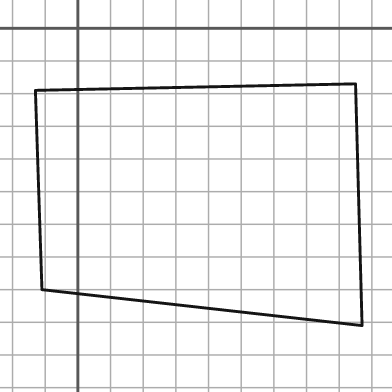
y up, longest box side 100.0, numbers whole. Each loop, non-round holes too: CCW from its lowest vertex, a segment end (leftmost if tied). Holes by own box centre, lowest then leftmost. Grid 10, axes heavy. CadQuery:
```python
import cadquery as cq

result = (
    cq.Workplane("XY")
    .moveTo(87.0, -91.0)
    .lineTo(85.0, -17.0)
    .lineTo(-13.0, -19.0)
    .lineTo(-11.0, -80.0)
    .close()
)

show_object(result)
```